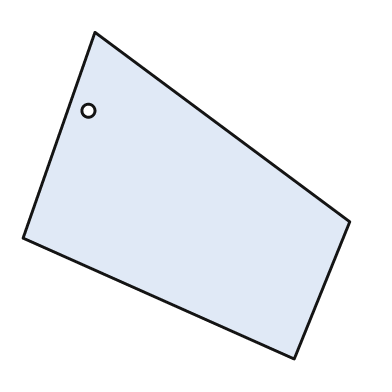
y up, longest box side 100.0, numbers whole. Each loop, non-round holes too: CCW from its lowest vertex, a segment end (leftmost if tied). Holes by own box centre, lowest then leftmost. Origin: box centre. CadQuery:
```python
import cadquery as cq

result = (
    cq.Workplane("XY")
    .moveTo(33.0, -50.0)
    .lineTo(50.0, -8.0)
    .lineTo(-28.0, 50.0)
    .lineTo(-50.0, -13.0)
    .close()
    .moveTo(-30.0, 26.0)
    .circle(2.0)
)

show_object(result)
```